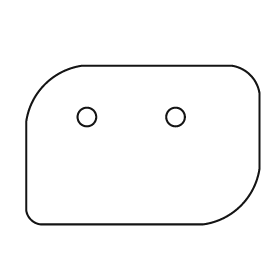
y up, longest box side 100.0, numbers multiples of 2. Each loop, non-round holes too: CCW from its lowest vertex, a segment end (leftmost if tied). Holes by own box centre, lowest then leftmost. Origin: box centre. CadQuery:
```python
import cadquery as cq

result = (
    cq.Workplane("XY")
    .moveTo(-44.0, -34.0)
    .lineTo(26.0, -34.0)
    .threePointArc((42.0, -26.0), (50.0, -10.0))
    .lineTo(50.0, 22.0)
    .threePointArc((46.0, 30.0), (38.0, 34.0))
    .lineTo(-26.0, 34.0)
    .threePointArc((-42.0, 26.0), (-50.0, 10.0))
    .lineTo(-50.0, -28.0)
    .threePointArc((-48.0, -32.0), (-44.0, -34.0))
    .close()
    .moveTo(-24.0, 12.0)
    .circle(4.0)
    .moveTo(14.0, 12.0)
    .circle(4.0)
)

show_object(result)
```